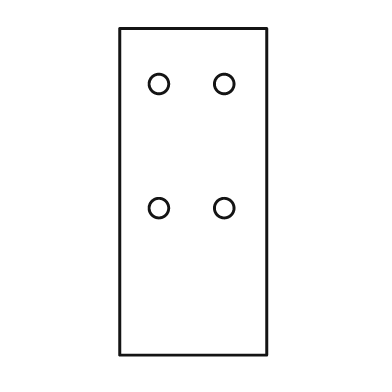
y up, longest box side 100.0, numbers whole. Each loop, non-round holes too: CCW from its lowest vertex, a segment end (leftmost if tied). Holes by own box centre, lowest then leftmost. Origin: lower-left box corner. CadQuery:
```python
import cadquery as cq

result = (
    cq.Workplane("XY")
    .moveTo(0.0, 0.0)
    .lineTo(45.0, 0.0)
    .lineTo(45.0, 100.0)
    .lineTo(0.0, 100.0)
    .close()
    .moveTo(12.0, 45.0)
    .circle(3.0)
    .moveTo(32.0, 45.0)
    .circle(3.0)
    .moveTo(12.0, 83.0)
    .circle(3.0)
    .moveTo(32.0, 83.0)
    .circle(3.0)
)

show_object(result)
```